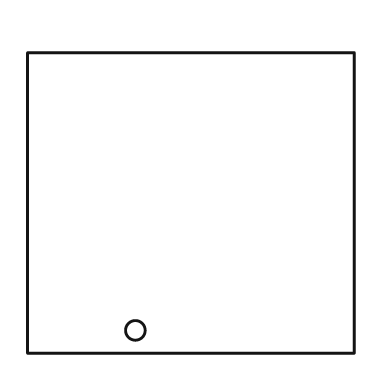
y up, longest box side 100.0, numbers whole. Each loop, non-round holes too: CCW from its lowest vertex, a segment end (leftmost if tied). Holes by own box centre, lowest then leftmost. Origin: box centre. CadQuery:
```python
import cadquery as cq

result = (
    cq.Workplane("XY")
    .moveTo(-50.0, -46.0)
    .lineTo(50.0, -46.0)
    .lineTo(50.0, 46.0)
    .lineTo(-50.0, 46.0)
    .close()
    .moveTo(-17.0, -39.0)
    .circle(3.0)
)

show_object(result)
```